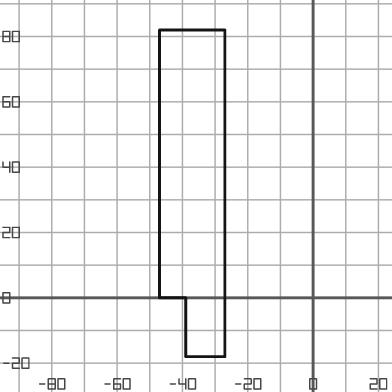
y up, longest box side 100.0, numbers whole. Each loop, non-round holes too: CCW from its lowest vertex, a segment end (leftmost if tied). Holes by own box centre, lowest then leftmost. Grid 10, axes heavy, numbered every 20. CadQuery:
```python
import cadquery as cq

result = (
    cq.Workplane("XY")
    .moveTo(-39.0, -18.0)
    .lineTo(-27.0, -18.0)
    .lineTo(-27.0, 82.0)
    .lineTo(-47.0, 82.0)
    .lineTo(-47.0, 0.0)
    .lineTo(-39.0, 0.0)
    .close()
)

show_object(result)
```